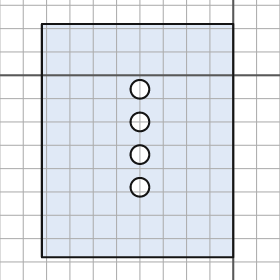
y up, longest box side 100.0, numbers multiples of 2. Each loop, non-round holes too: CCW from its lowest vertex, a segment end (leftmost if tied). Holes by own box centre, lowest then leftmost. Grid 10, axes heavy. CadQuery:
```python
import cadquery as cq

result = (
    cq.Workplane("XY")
    .moveTo(-82.0, -78.0)
    .lineTo(0.0, -78.0)
    .lineTo(0.0, 22.0)
    .lineTo(-82.0, 22.0)
    .close()
    .moveTo(-40.0, -48.0)
    .circle(4.0)
    .moveTo(-40.0, -34.0)
    .circle(4.0)
    .moveTo(-40.0, -20.0)
    .circle(4.0)
    .moveTo(-40.0, -6.0)
    .circle(4.0)
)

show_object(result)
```